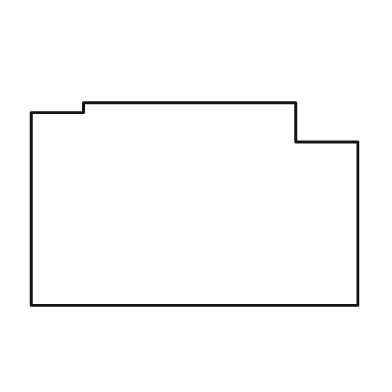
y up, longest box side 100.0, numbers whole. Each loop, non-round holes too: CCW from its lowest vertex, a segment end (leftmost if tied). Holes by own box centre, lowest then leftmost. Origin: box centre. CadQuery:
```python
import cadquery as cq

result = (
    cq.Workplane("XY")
    .moveTo(-50.0, -31.0)
    .lineTo(50.0, -31.0)
    .lineTo(50.0, 19.0)
    .lineTo(31.0, 19.0)
    .lineTo(31.0, 31.0)
    .lineTo(-34.0, 31.0)
    .lineTo(-34.0, 28.0)
    .lineTo(-50.0, 28.0)
    .close()
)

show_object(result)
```